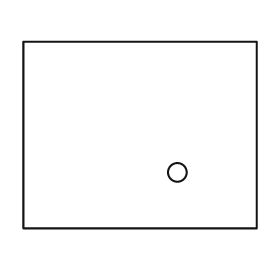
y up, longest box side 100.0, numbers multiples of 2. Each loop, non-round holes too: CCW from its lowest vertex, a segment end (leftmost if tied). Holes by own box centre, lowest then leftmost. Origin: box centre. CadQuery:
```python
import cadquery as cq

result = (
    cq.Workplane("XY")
    .moveTo(-50.0, -40.0)
    .lineTo(50.0, -40.0)
    .lineTo(50.0, 40.0)
    .lineTo(-50.0, 40.0)
    .close()
    .moveTo(16.0, -16.0)
    .circle(4.0)
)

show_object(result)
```